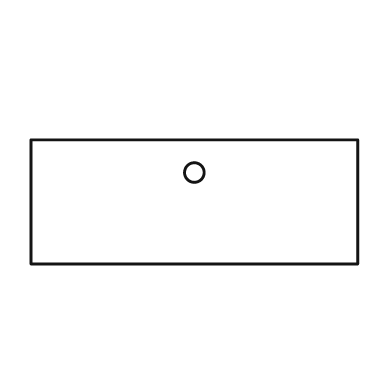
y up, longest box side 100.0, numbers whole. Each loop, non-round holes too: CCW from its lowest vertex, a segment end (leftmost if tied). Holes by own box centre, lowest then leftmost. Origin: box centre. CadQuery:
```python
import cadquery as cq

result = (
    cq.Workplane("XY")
    .moveTo(-50.0, -19.0)
    .lineTo(50.0, -19.0)
    .lineTo(50.0, 19.0)
    .lineTo(-50.0, 19.0)
    .close()
    .moveTo(0.0, 9.0)
    .circle(3.0)
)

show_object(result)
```